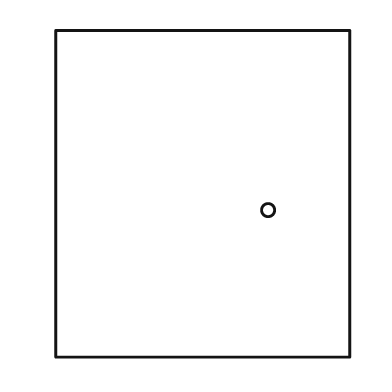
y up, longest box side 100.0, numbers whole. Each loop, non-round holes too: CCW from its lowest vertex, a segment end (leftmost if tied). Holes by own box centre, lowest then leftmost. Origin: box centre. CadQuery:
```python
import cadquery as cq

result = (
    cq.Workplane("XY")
    .moveTo(-45.0, -50.0)
    .lineTo(45.0, -50.0)
    .lineTo(45.0, 50.0)
    .lineTo(-45.0, 50.0)
    .close()
    .moveTo(20.0, -5.0)
    .circle(2.0)
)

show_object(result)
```